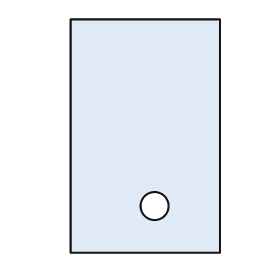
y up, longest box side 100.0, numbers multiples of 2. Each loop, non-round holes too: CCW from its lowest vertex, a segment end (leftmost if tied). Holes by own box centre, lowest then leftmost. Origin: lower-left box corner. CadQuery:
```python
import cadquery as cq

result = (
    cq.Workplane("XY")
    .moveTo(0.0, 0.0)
    .lineTo(64.0, 0.0)
    .lineTo(64.0, 100.0)
    .lineTo(0.0, 100.0)
    .close()
    .moveTo(36.0, 20.0)
    .circle(6.0)
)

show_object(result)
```